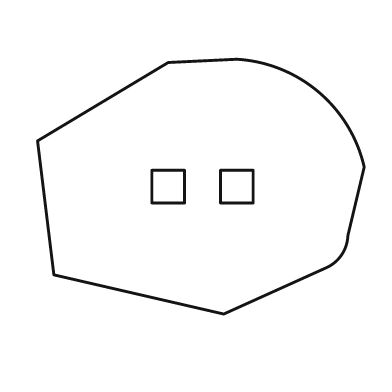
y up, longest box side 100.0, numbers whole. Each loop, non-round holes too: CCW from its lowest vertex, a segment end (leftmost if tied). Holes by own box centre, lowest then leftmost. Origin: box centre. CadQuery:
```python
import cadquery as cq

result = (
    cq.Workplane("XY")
    .moveTo(7.0, -39.0)
    .lineTo(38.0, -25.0)
    .threePointArc((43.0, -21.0), (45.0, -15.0))
    .lineTo(50.0, 6.0)
    .threePointArc((36.0, 29.0), (11.0, 39.0))
    .lineTo(-10.0, 38.0)
    .lineTo(-50.0, 14.0)
    .lineTo(-45.0, -27.0)
    .close()
    .moveTo(-15.0, -5.0)
    .lineTo(-5.0, -5.0)
    .lineTo(-5.0, 5.0)
    .lineTo(-15.0, 5.0)
    .close()
    .moveTo(6.0, -5.0)
    .lineTo(16.0, -5.0)
    .lineTo(16.0, 5.0)
    .lineTo(6.0, 5.0)
    .close()
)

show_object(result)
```